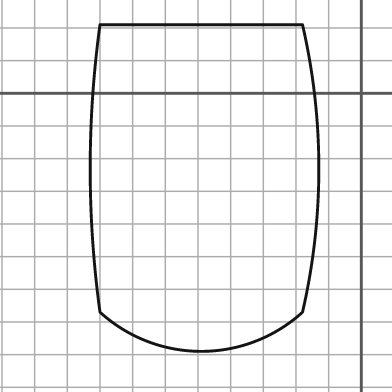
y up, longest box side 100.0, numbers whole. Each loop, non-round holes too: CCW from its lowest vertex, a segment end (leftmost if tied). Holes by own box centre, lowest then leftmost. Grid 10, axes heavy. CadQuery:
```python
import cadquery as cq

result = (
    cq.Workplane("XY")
    .moveTo(-80.0, -67.0)
    .threePointArc((-49.0, -79.0), (-18.0, -67.0))
    .threePointArc((-13.0, -23.0), (-18.0, 21.0))
    .lineTo(-80.0, 21.0)
    .threePointArc((-83.0, -23.0), (-80.0, -67.0))
    .close()
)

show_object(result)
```